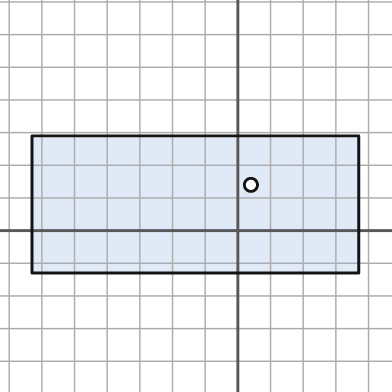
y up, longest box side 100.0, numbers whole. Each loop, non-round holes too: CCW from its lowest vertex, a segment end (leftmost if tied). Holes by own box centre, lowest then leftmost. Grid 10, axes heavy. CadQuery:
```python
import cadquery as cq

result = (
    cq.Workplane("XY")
    .moveTo(-63.0, -13.0)
    .lineTo(37.0, -13.0)
    .lineTo(37.0, 29.0)
    .lineTo(-63.0, 29.0)
    .close()
    .moveTo(4.0, 14.0)
    .circle(2.0)
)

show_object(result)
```